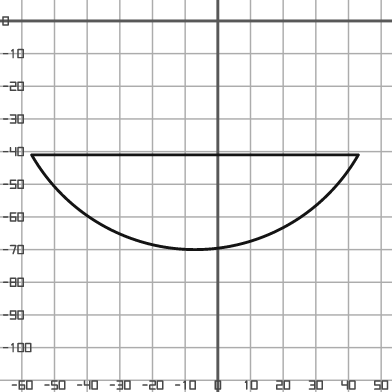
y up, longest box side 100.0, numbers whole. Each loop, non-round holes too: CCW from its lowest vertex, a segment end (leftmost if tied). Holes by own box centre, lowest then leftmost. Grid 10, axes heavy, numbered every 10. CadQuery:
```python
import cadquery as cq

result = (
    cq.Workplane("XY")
    .moveTo(-57.0, -41.0)
    .threePointArc((-7.0, -70.0), (43.0, -41.0))
    .close()
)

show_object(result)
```